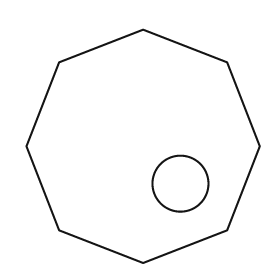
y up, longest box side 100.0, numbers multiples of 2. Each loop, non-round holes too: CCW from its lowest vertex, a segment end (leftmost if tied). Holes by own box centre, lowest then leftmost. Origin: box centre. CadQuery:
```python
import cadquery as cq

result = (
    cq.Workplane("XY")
    .moveTo(0.0, -50.0)
    .lineTo(36.0, -36.0)
    .lineTo(50.0, 0.0)
    .lineTo(36.0, 36.0)
    .lineTo(0.0, 50.0)
    .lineTo(-36.0, 36.0)
    .lineTo(-50.0, 0.0)
    .lineTo(-36.0, -36.0)
    .close()
    .moveTo(16.0, -16.0)
    .circle(12.0)
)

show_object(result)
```